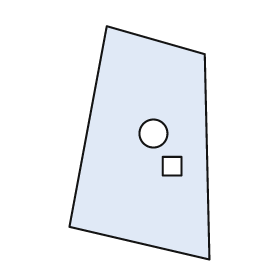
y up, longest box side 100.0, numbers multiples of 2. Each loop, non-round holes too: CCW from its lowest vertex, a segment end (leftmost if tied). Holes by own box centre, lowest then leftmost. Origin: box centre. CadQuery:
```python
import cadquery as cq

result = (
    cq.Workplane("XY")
    .moveTo(30.0, -50.0)
    .lineTo(28.0, 38.0)
    .lineTo(-14.0, 50.0)
    .lineTo(-30.0, -36.0)
    .close()
    .moveTo(10.0, -14.0)
    .lineTo(18.0, -14.0)
    .lineTo(18.0, -6.0)
    .lineTo(10.0, -6.0)
    .close()
    .moveTo(6.0, 4.0)
    .circle(6.0)
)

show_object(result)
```